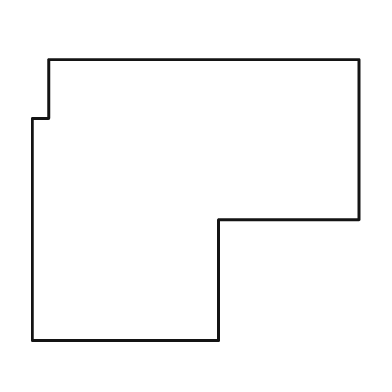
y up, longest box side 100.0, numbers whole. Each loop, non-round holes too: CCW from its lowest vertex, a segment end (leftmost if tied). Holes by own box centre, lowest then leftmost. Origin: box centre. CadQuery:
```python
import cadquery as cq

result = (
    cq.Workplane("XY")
    .moveTo(-50.0, -43.0)
    .lineTo(7.0, -43.0)
    .lineTo(7.0, -6.0)
    .lineTo(50.0, -6.0)
    .lineTo(50.0, 43.0)
    .lineTo(-45.0, 43.0)
    .lineTo(-45.0, 25.0)
    .lineTo(-50.0, 25.0)
    .close()
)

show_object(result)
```